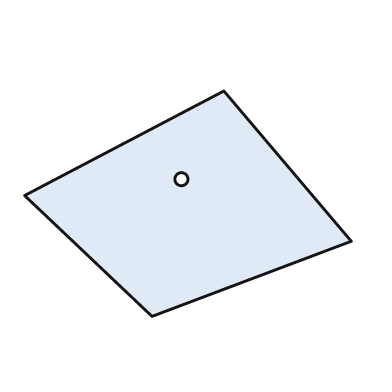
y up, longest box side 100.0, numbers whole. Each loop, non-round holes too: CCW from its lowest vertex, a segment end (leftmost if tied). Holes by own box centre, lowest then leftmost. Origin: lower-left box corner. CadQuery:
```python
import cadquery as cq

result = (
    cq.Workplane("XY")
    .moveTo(39.0, 0.0)
    .lineTo(100.0, 23.0)
    .lineTo(61.0, 69.0)
    .lineTo(0.0, 37.0)
    .close()
    .moveTo(48.0, 42.0)
    .circle(2.0)
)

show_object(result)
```